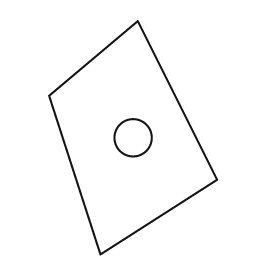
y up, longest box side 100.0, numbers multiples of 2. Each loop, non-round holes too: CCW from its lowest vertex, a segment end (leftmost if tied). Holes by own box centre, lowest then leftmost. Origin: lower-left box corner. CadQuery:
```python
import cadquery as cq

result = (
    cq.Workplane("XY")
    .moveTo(22.0, 0.0)
    .lineTo(72.0, 32.0)
    .lineTo(38.0, 100.0)
    .lineTo(0.0, 68.0)
    .close()
    .moveTo(36.0, 50.0)
    .circle(8.0)
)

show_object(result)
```